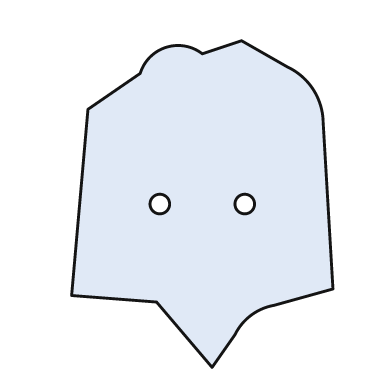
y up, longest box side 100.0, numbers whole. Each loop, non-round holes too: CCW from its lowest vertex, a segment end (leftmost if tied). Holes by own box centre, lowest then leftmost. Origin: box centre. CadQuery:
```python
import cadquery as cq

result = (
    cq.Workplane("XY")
    .moveTo(3.0, -50.0)
    .lineTo(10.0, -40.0)
    .threePointArc((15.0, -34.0), (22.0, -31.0))
    .lineTo(40.0, -26.0)
    .lineTo(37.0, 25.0)
    .threePointArc((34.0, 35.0), (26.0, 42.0))
    .lineTo(12.0, 50.0)
    .lineTo(0.0, 46.0)
    .threePointArc((-11.0, 48.0), (-19.0, 40.0))
    .lineTo(-35.0, 29.0)
    .lineTo(-40.0, -28.0)
    .lineTo(-14.0, -30.0)
    .close()
    .moveTo(-13.0, 0.0)
    .circle(3.0)
    .moveTo(13.0, 0.0)
    .circle(3.0)
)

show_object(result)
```